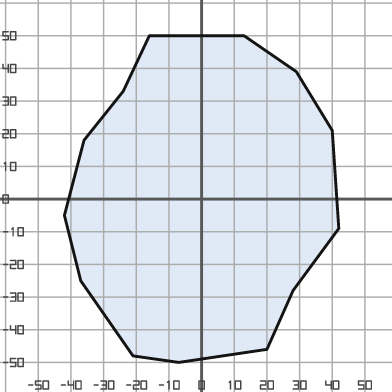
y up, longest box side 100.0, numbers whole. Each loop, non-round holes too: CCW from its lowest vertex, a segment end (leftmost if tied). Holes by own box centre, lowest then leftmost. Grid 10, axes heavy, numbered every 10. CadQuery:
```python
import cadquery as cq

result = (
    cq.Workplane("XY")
    .moveTo(-7.0, -50.0)
    .lineTo(20.0, -46.0)
    .lineTo(28.0, -28.0)
    .lineTo(42.0, -9.0)
    .lineTo(40.0, 21.0)
    .lineTo(29.0, 39.0)
    .lineTo(13.0, 50.0)
    .lineTo(-16.0, 50.0)
    .lineTo(-24.0, 33.0)
    .lineTo(-36.0, 18.0)
    .lineTo(-42.0, -5.0)
    .lineTo(-37.0, -25.0)
    .lineTo(-21.0, -48.0)
    .close()
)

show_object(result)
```